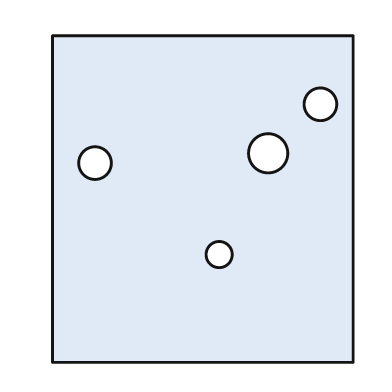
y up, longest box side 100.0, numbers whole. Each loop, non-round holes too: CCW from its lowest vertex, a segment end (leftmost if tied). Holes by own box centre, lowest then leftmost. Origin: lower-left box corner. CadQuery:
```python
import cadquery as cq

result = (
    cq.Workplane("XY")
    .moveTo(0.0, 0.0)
    .lineTo(92.0, 0.0)
    .lineTo(92.0, 100.0)
    .lineTo(0.0, 100.0)
    .close()
    .moveTo(51.0, 33.0)
    .circle(4.0)
    .moveTo(13.0, 61.0)
    .circle(5.0)
    .moveTo(66.0, 64.0)
    .circle(6.0)
    .moveTo(82.0, 79.0)
    .circle(5.0)
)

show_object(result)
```